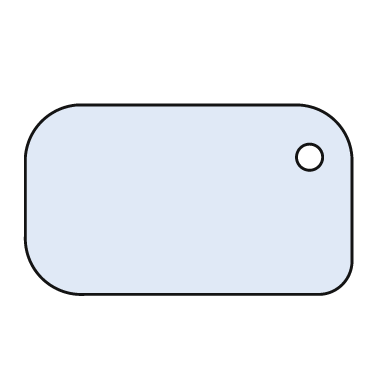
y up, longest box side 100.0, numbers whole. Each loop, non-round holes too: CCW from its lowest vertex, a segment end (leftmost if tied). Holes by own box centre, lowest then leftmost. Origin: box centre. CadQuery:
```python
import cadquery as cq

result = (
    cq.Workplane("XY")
    .moveTo(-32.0, -29.0)
    .lineTo(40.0, -29.0)
    .threePointArc((47.0, -26.0), (50.0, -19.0))
    .lineTo(50.0, 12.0)
    .threePointArc((45.0, 24.0), (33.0, 29.0))
    .lineTo(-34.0, 29.0)
    .threePointArc((-45.0, 24.0), (-50.0, 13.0))
    .lineTo(-50.0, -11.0)
    .threePointArc((-45.0, -24.0), (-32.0, -29.0))
    .close()
    .moveTo(37.0, 13.0)
    .circle(4.0)
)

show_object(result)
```